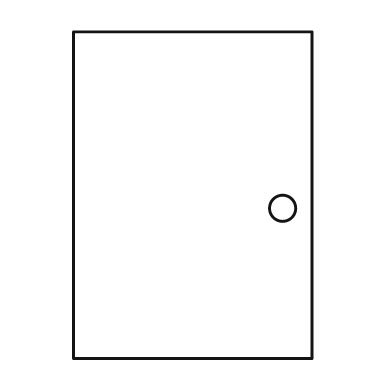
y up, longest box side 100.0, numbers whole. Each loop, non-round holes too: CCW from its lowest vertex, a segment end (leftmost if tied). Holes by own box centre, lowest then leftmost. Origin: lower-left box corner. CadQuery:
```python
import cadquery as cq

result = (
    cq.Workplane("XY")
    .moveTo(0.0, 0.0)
    .lineTo(73.0, 0.0)
    .lineTo(73.0, 100.0)
    .lineTo(0.0, 100.0)
    .close()
    .moveTo(64.0, 46.0)
    .circle(4.0)
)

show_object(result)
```